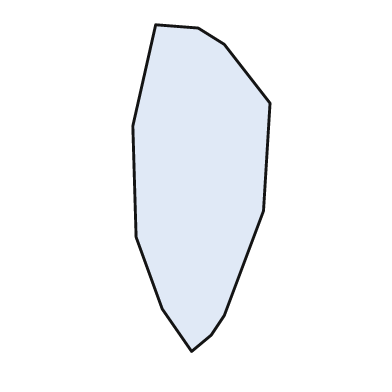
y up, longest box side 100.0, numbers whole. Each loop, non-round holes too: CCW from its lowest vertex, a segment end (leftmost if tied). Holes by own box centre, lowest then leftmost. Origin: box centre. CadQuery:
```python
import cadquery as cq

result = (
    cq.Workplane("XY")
    .moveTo(-3.0, -50.0)
    .lineTo(3.0, -45.0)
    .lineTo(7.0, -39.0)
    .lineTo(19.0, -7.0)
    .lineTo(21.0, 26.0)
    .lineTo(7.0, 44.0)
    .lineTo(-1.0, 49.0)
    .lineTo(-14.0, 50.0)
    .lineTo(-21.0, 19.0)
    .lineTo(-20.0, -15.0)
    .lineTo(-12.0, -37.0)
    .close()
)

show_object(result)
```